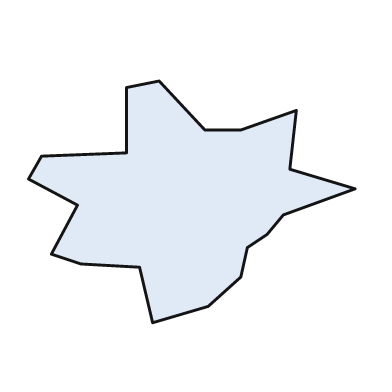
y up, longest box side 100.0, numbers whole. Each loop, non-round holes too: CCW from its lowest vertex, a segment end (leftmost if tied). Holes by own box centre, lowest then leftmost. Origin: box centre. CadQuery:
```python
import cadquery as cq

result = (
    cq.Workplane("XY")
    .moveTo(-12.0, -37.0)
    .lineTo(5.0, -32.0)
    .lineTo(15.0, -23.0)
    .lineTo(17.0, -14.0)
    .lineTo(23.0, -10.0)
    .lineTo(28.0, -4.0)
    .lineTo(50.0, 4.0)
    .lineTo(30.0, 10.0)
    .lineTo(32.0, 28.0)
    .lineTo(15.0, 22.0)
    .lineTo(4.0, 22.0)
    .lineTo(-10.0, 37.0)
    .lineTo(-20.0, 35.0)
    .lineTo(-20.0, 15.0)
    .lineTo(-46.0, 14.0)
    .lineTo(-50.0, 7.0)
    .lineTo(-35.0, -1.0)
    .lineTo(-43.0, -16.0)
    .lineTo(-34.0, -19.0)
    .lineTo(-16.0, -20.0)
    .close()
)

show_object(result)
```